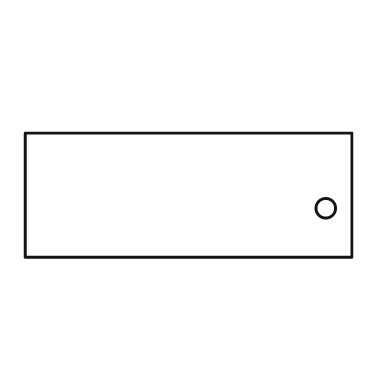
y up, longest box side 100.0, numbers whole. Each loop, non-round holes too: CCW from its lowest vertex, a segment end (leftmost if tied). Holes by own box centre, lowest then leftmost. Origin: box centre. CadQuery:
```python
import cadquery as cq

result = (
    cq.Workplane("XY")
    .moveTo(-50.0, -19.0)
    .lineTo(50.0, -19.0)
    .lineTo(50.0, 19.0)
    .lineTo(-50.0, 19.0)
    .close()
    .moveTo(42.0, -4.0)
    .circle(3.0)
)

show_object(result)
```